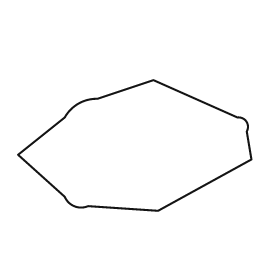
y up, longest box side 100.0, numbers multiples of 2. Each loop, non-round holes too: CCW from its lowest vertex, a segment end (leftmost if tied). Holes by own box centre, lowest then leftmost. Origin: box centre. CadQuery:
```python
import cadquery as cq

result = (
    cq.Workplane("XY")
    .moveTo(10.0, -28.0)
    .lineTo(50.0, -6.0)
    .lineTo(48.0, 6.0)
    .threePointArc((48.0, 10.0), (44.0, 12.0))
    .lineTo(8.0, 28.0)
    .lineTo(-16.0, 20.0)
    .threePointArc((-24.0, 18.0), (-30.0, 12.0))
    .lineTo(-50.0, -4.0)
    .lineTo(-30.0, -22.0)
    .threePointArc((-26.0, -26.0), (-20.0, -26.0))
    .close()
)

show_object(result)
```